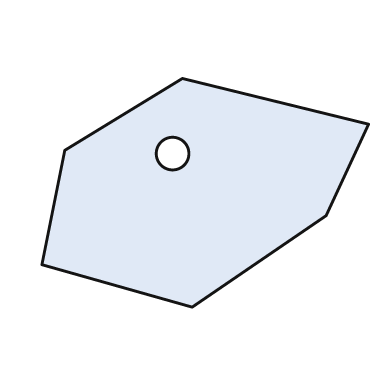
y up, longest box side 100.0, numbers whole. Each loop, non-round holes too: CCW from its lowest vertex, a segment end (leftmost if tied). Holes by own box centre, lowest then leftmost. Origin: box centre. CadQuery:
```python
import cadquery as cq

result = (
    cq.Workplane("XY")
    .moveTo(-4.0, -35.0)
    .lineTo(37.0, -7.0)
    .lineTo(50.0, 21.0)
    .lineTo(-7.0, 35.0)
    .lineTo(-43.0, 13.0)
    .lineTo(-50.0, -22.0)
    .close()
    .moveTo(-10.0, 12.0)
    .circle(5.0)
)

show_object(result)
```